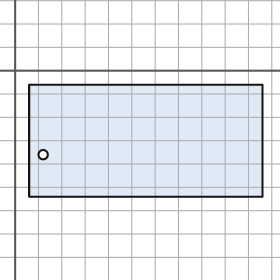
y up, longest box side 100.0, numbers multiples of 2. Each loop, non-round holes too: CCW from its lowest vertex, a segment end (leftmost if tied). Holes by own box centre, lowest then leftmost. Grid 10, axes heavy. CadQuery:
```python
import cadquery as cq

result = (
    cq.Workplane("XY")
    .moveTo(6.0, -54.0)
    .lineTo(106.0, -54.0)
    .lineTo(106.0, -6.0)
    .lineTo(6.0, -6.0)
    .close()
    .moveTo(12.0, -36.0)
    .circle(2.0)
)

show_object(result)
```